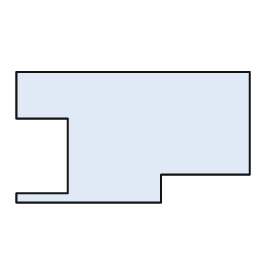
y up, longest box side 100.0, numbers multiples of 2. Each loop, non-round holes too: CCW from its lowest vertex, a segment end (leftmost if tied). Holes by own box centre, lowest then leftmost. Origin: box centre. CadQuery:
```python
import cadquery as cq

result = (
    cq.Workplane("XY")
    .moveTo(-50.0, -28.0)
    .lineTo(12.0, -28.0)
    .lineTo(12.0, -16.0)
    .lineTo(50.0, -16.0)
    .lineTo(50.0, 28.0)
    .lineTo(-50.0, 28.0)
    .lineTo(-50.0, 8.0)
    .lineTo(-28.0, 8.0)
    .lineTo(-28.0, -24.0)
    .lineTo(-50.0, -24.0)
    .close()
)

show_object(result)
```